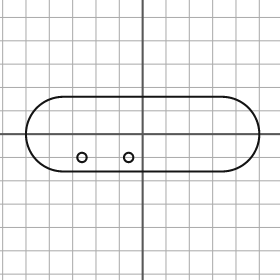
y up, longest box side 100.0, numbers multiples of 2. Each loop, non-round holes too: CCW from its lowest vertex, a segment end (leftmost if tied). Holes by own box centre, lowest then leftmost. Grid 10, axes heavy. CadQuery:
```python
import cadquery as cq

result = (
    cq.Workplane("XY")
    .moveTo(-34.0, -16.0)
    .lineTo(34.0, -16.0)
    .threePointArc((50.0, 0.0), (34.0, 16.0))
    .lineTo(-34.0, 16.0)
    .threePointArc((-50.0, 0.0), (-34.0, -16.0))
    .close()
    .moveTo(-26.0, -10.0)
    .circle(2.0)
    .moveTo(-6.0, -10.0)
    .circle(2.0)
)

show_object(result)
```